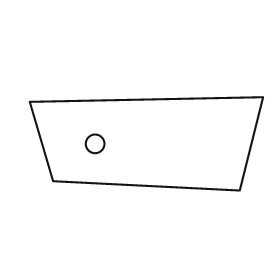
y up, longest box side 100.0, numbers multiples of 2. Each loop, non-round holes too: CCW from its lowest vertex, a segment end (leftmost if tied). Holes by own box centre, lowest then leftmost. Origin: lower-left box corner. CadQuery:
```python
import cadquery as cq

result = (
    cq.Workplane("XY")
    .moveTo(90.0, 0.0)
    .lineTo(100.0, 40.0)
    .lineTo(0.0, 38.0)
    .lineTo(10.0, 4.0)
    .close()
    .moveTo(28.0, 20.0)
    .circle(4.0)
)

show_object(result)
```